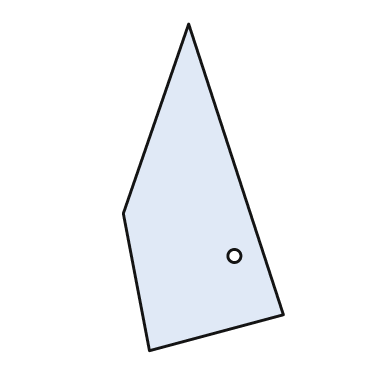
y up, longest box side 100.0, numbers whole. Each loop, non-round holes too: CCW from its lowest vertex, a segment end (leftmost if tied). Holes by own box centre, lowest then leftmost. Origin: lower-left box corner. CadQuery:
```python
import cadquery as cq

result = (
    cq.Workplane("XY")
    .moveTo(8.0, 0.0)
    .lineTo(49.0, 11.0)
    .lineTo(20.0, 100.0)
    .lineTo(0.0, 42.0)
    .close()
    .moveTo(34.0, 29.0)
    .circle(2.0)
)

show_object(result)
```